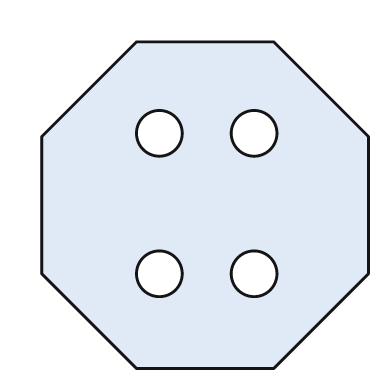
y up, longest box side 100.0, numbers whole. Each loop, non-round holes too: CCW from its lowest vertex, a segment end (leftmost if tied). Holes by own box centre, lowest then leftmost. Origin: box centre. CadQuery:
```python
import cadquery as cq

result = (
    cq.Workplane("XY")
    .moveTo(-21.0, -50.0)
    .lineTo(21.0, -50.0)
    .lineTo(50.0, -21.0)
    .lineTo(50.0, 21.0)
    .lineTo(21.0, 50.0)
    .lineTo(-21.0, 50.0)
    .lineTo(-50.0, 21.0)
    .lineTo(-50.0, -21.0)
    .close()
    .moveTo(-14.0, -21.0)
    .circle(7.0)
    .moveTo(15.0, -21.0)
    .circle(7.0)
    .moveTo(-14.0, 22.0)
    .circle(7.0)
    .moveTo(15.0, 22.0)
    .circle(7.0)
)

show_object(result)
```